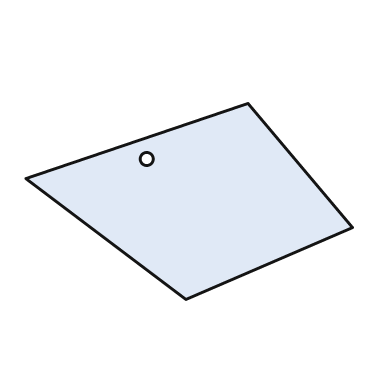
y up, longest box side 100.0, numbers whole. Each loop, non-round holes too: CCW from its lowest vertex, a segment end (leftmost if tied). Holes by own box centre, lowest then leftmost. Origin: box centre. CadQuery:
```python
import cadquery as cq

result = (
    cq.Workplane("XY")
    .moveTo(-1.0, -30.0)
    .lineTo(50.0, -8.0)
    .lineTo(18.0, 30.0)
    .lineTo(-50.0, 7.0)
    .close()
    .moveTo(-13.0, 13.0)
    .circle(2.0)
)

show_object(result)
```